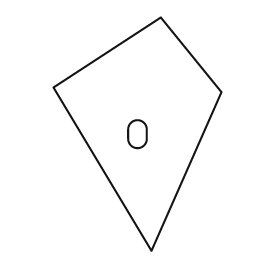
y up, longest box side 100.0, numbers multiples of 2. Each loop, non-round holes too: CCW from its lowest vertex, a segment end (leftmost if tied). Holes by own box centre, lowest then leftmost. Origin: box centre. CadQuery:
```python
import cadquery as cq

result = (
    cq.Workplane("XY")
    .moveTo(6.0, -50.0)
    .lineTo(36.0, 18.0)
    .lineTo(10.0, 50.0)
    .lineTo(-36.0, 20.0)
    .close()
    .moveTo(-4.0, -2.0)
    .threePointArc((0.0, -6.0), (4.0, -2.0))
    .lineTo(4.0, 2.0)
    .threePointArc((0.0, 6.0), (-4.0, 2.0))
    .close()
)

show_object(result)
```